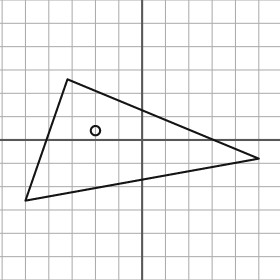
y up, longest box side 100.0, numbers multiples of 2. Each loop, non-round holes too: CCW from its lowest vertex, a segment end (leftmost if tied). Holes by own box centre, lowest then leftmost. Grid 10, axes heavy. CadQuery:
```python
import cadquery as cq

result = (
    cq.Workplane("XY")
    .moveTo(-50.0, -26.0)
    .lineTo(50.0, -8.0)
    .lineTo(-32.0, 26.0)
    .close()
    .moveTo(-20.0, 4.0)
    .circle(2.0)
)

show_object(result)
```